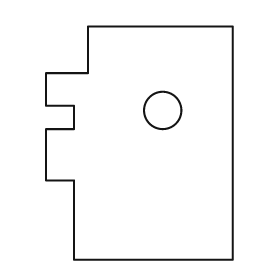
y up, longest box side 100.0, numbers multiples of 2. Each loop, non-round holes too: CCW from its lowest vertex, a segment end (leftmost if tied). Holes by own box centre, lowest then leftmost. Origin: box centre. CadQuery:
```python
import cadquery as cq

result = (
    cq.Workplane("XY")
    .moveTo(-28.0, -50.0)
    .lineTo(40.0, -50.0)
    .lineTo(40.0, 50.0)
    .lineTo(-22.0, 50.0)
    .lineTo(-22.0, 30.0)
    .lineTo(-40.0, 30.0)
    .lineTo(-40.0, 16.0)
    .lineTo(-28.0, 16.0)
    .lineTo(-28.0, 6.0)
    .lineTo(-40.0, 6.0)
    .lineTo(-40.0, -16.0)
    .lineTo(-28.0, -16.0)
    .close()
    .moveTo(10.0, 14.0)
    .circle(8.0)
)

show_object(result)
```